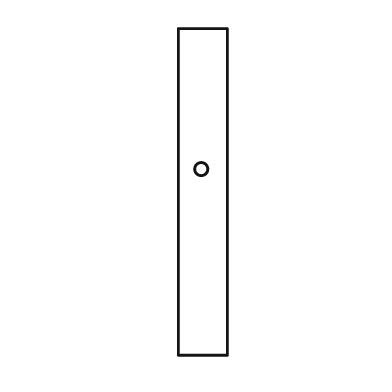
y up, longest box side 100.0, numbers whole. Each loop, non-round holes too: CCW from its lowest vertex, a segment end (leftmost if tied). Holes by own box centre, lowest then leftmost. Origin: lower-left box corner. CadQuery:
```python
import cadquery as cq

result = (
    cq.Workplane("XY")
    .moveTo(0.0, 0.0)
    .lineTo(15.0, 0.0)
    .lineTo(15.0, 100.0)
    .lineTo(0.0, 100.0)
    .close()
    .moveTo(7.0, 57.0)
    .circle(2.0)
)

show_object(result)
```